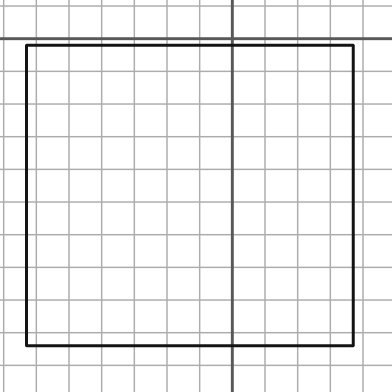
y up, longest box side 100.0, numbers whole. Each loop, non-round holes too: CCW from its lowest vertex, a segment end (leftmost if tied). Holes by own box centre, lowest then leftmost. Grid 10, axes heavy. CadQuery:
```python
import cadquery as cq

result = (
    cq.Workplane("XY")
    .moveTo(-63.0, -94.0)
    .lineTo(37.0, -94.0)
    .lineTo(37.0, -2.0)
    .lineTo(-63.0, -2.0)
    .close()
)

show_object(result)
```